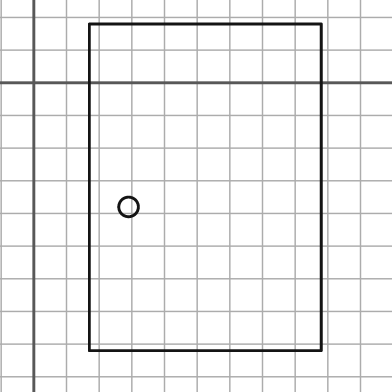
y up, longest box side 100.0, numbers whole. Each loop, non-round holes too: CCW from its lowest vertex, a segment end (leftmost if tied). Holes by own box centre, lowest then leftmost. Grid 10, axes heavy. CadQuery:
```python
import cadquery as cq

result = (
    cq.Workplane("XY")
    .moveTo(17.0, -82.0)
    .lineTo(88.0, -82.0)
    .lineTo(88.0, 18.0)
    .lineTo(17.0, 18.0)
    .close()
    .moveTo(29.0, -38.0)
    .circle(3.0)
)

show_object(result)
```